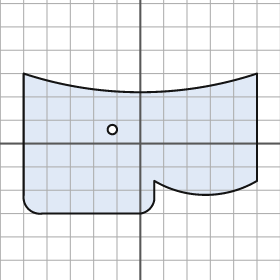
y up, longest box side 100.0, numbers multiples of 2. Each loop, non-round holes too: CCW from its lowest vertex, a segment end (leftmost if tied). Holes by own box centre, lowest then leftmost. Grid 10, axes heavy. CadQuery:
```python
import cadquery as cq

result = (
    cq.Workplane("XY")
    .moveTo(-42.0, -30.0)
    .lineTo(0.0, -30.0)
    .threePointArc((4.0, -28.0), (6.0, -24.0))
    .lineTo(6.0, -16.0)
    .threePointArc((28.0, -22.0), (50.0, -16.0))
    .lineTo(50.0, 30.0)
    .threePointArc((0.0, 22.0), (-50.0, 30.0))
    .lineTo(-50.0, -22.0)
    .threePointArc((-48.0, -28.0), (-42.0, -30.0))
    .close()
    .moveTo(-12.0, 6.0)
    .circle(2.0)
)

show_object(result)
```